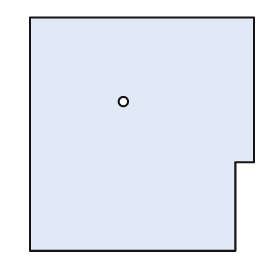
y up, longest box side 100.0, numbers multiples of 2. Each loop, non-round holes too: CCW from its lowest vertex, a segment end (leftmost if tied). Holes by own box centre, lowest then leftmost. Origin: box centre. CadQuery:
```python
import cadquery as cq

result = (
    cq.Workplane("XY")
    .moveTo(-48.0, -50.0)
    .lineTo(40.0, -50.0)
    .lineTo(40.0, -12.0)
    .lineTo(48.0, -12.0)
    .lineTo(48.0, 50.0)
    .lineTo(-48.0, 50.0)
    .close()
    .moveTo(-8.0, 14.0)
    .circle(2.0)
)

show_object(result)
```